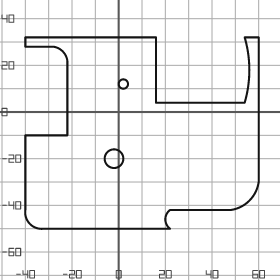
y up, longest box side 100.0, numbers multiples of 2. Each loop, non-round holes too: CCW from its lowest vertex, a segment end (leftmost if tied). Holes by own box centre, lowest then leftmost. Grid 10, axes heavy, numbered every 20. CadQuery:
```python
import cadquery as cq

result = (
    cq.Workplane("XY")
    .moveTo(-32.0, -50.0)
    .lineTo(22.0, -50.0)
    .threePointArc((20.0, -46.0), (22.0, -42.0))
    .lineTo(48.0, -42.0)
    .threePointArc((56.0, -38.0), (60.0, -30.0))
    .lineTo(60.0, 32.0)
    .lineTo(54.0, 32.0)
    .threePointArc((56.0, 18.0), (54.0, 4.0))
    .lineTo(16.0, 4.0)
    .lineTo(16.0, 32.0)
    .lineTo(-40.0, 32.0)
    .lineTo(-40.0, 28.0)
    .lineTo(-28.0, 28.0)
    .threePointArc((-24.0, 26.0), (-22.0, 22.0))
    .lineTo(-22.0, -10.0)
    .lineTo(-40.0, -10.0)
    .lineTo(-40.0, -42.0)
    .threePointArc((-38.0, -48.0), (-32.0, -50.0))
    .close()
    .moveTo(-2.0, -20.0)
    .circle(4.0)
    .moveTo(2.0, 12.0)
    .circle(2.0)
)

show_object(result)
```